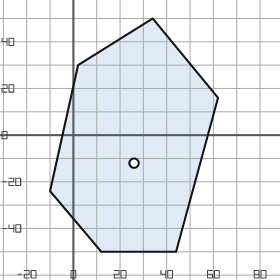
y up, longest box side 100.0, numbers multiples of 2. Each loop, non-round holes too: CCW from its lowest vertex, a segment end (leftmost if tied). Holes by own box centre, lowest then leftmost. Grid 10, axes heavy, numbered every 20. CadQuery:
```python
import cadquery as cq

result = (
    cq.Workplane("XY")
    .moveTo(12.0, -50.0)
    .lineTo(44.0, -50.0)
    .lineTo(62.0, 16.0)
    .lineTo(34.0, 50.0)
    .lineTo(2.0, 30.0)
    .lineTo(-10.0, -24.0)
    .close()
    .moveTo(26.0, -12.0)
    .circle(2.0)
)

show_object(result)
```